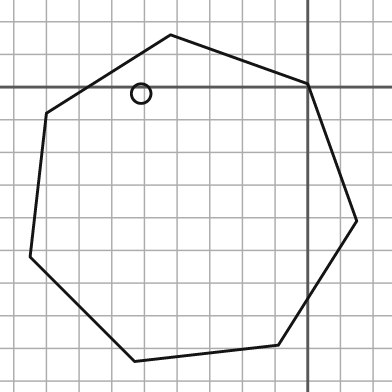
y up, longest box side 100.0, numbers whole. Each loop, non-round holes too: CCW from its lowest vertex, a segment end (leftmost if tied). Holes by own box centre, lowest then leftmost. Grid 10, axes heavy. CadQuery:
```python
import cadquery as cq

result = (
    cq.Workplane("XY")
    .moveTo(-53.0, -84.0)
    .lineTo(-9.0, -79.0)
    .lineTo(15.0, -41.0)
    .lineTo(0.0, 1.0)
    .lineTo(-42.0, 16.0)
    .lineTo(-80.0, -8.0)
    .lineTo(-85.0, -52.0)
    .close()
    .moveTo(-51.0, -2.0)
    .circle(3.0)
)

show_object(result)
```